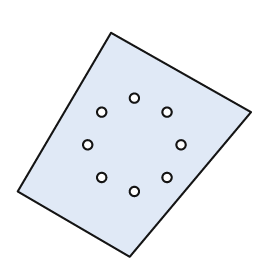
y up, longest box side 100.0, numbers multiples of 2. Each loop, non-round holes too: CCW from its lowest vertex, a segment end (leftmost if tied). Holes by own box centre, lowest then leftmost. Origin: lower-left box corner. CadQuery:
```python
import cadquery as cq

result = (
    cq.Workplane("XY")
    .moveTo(48.0, 0.0)
    .lineTo(100.0, 62.0)
    .lineTo(40.0, 96.0)
    .lineTo(0.0, 28.0)
    .close()
    .moveTo(50.0, 28.0)
    .circle(2.0)
    .moveTo(36.0, 34.0)
    .circle(2.0)
    .moveTo(64.0, 34.0)
    .circle(2.0)
    .moveTo(30.0, 48.0)
    .circle(2.0)
    .moveTo(70.0, 48.0)
    .circle(2.0)
    .moveTo(36.0, 62.0)
    .circle(2.0)
    .moveTo(64.0, 62.0)
    .circle(2.0)
    .moveTo(50.0, 68.0)
    .circle(2.0)
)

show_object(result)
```